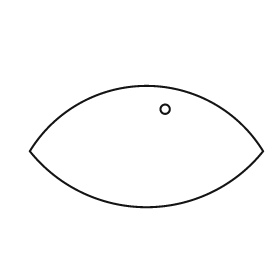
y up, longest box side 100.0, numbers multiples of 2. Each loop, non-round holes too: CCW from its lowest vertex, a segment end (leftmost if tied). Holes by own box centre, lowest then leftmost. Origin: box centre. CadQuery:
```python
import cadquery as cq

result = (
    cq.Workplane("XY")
    .moveTo(-50.0, -2.0)
    .threePointArc((0.0, -26.0), (50.0, -2.0))
    .threePointArc((0.0, 26.0), (-50.0, -2.0))
    .close()
    .moveTo(8.0, 16.0)
    .circle(2.0)
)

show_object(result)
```